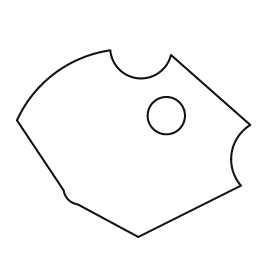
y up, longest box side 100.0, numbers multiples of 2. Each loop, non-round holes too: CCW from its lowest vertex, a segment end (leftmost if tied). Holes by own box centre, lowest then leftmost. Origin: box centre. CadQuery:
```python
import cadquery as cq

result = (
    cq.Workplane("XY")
    .moveTo(2.0, -40.0)
    .lineTo(46.0, -18.0)
    .threePointArc((42.0, -4.0), (50.0, 8.0))
    .lineTo(16.0, 38.0)
    .threePointArc((2.0, 28.0), (-10.0, 40.0))
    .threePointArc((-34.0, 30.0), (-50.0, 10.0))
    .lineTo(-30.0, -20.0)
    .threePointArc((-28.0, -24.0), (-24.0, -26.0))
    .close()
    .moveTo(14.0, 12.0)
    .circle(8.0)
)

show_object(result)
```